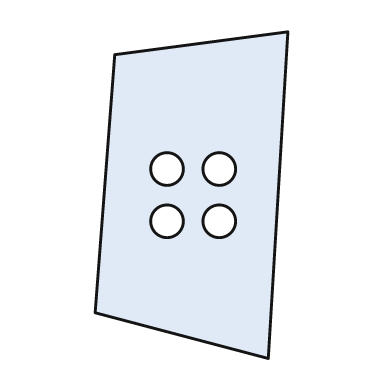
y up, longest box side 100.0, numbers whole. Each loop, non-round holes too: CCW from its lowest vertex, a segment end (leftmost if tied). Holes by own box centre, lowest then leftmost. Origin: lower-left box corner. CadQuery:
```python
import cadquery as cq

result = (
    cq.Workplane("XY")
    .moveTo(53.0, 0.0)
    .lineTo(59.0, 100.0)
    .lineTo(6.0, 93.0)
    .lineTo(0.0, 14.0)
    .close()
    .moveTo(22.0, 42.0)
    .circle(5.0)
    .moveTo(38.0, 42.0)
    .circle(5.0)
    .moveTo(22.0, 58.0)
    .circle(5.0)
    .moveTo(38.0, 58.0)
    .circle(5.0)
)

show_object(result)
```